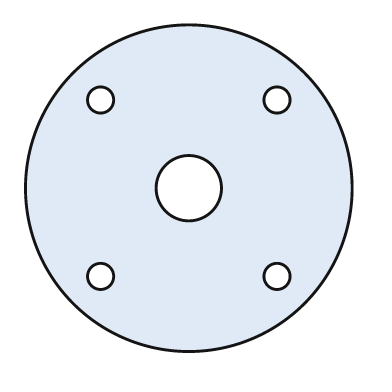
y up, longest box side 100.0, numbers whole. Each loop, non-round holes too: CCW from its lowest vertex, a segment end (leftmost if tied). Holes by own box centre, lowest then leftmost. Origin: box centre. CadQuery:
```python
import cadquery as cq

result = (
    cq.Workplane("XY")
    .moveTo(0.0, 0.0)
    .circle(50.0)
    .moveTo(-27.0, -27.0)
    .circle(4.0)
    .moveTo(27.0, -27.0)
    .circle(4.0)
    .moveTo(0.0, 0.0)
    .circle(10.0)
    .moveTo(-27.0, 27.0)
    .circle(4.0)
    .moveTo(27.0, 27.0)
    .circle(4.0)
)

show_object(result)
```